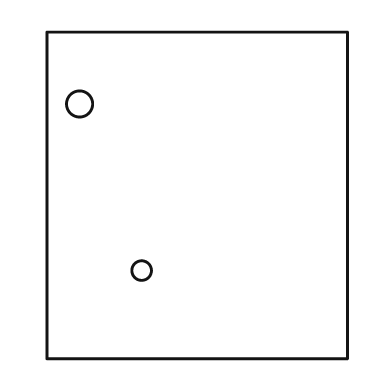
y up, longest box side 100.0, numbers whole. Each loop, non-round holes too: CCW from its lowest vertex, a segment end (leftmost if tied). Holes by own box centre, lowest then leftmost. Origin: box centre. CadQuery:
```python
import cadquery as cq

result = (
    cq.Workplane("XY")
    .moveTo(-46.0, -50.0)
    .lineTo(46.0, -50.0)
    .lineTo(46.0, 50.0)
    .lineTo(-46.0, 50.0)
    .close()
    .moveTo(-17.0, -23.0)
    .circle(3.0)
    .moveTo(-36.0, 28.0)
    .circle(4.0)
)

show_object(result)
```